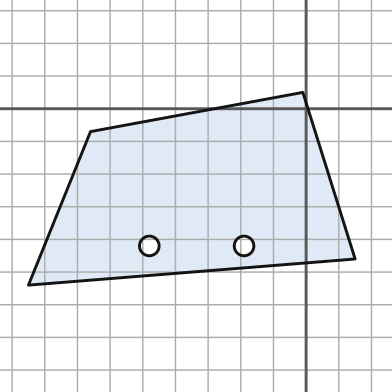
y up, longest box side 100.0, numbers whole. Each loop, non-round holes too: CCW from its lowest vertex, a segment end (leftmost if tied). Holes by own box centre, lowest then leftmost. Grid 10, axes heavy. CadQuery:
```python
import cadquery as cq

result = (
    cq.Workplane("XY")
    .moveTo(-85.0, -54.0)
    .lineTo(15.0, -46.0)
    .lineTo(-1.0, 5.0)
    .lineTo(-66.0, -7.0)
    .close()
    .moveTo(-48.0, -42.0)
    .circle(3.0)
    .moveTo(-19.0, -42.0)
    .circle(3.0)
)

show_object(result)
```